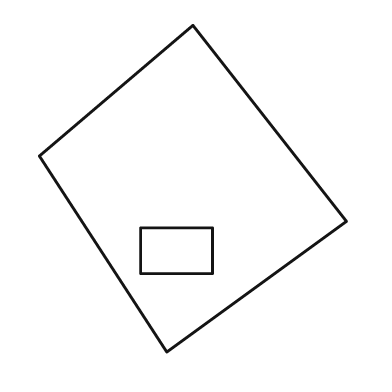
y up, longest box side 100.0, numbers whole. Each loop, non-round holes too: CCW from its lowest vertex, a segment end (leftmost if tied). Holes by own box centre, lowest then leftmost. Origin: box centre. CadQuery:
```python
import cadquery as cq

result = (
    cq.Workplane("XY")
    .moveTo(-8.0, -50.0)
    .lineTo(47.0, -10.0)
    .lineTo(0.0, 50.0)
    .lineTo(-47.0, 10.0)
    .close()
    .moveTo(-16.0, -26.0)
    .lineTo(6.0, -26.0)
    .lineTo(6.0, -12.0)
    .lineTo(-16.0, -12.0)
    .close()
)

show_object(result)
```